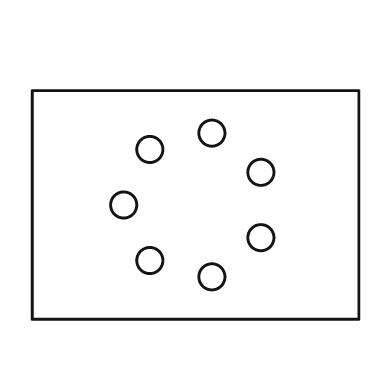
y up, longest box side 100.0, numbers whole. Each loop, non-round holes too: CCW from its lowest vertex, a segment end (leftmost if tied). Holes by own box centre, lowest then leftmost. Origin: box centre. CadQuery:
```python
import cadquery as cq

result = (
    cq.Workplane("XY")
    .moveTo(-50.0, -35.0)
    .lineTo(50.0, -35.0)
    .lineTo(50.0, 35.0)
    .lineTo(-50.0, 35.0)
    .close()
    .moveTo(5.0, -22.0)
    .circle(4.0)
    .moveTo(-14.0, -17.0)
    .circle(4.0)
    .moveTo(20.0, -10.0)
    .circle(4.0)
    .moveTo(-22.0, 0.0)
    .circle(4.0)
    .moveTo(20.0, 10.0)
    .circle(4.0)
    .moveTo(-14.0, 17.0)
    .circle(4.0)
    .moveTo(5.0, 22.0)
    .circle(4.0)
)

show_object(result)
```